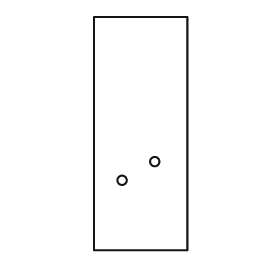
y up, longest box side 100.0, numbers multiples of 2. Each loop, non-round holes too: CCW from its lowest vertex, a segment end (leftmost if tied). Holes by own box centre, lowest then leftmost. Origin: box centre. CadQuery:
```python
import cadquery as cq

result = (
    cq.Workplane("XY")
    .moveTo(-20.0, -50.0)
    .lineTo(20.0, -50.0)
    .lineTo(20.0, 50.0)
    .lineTo(-20.0, 50.0)
    .close()
    .moveTo(-8.0, -20.0)
    .circle(2.0)
    .moveTo(6.0, -12.0)
    .circle(2.0)
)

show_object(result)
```